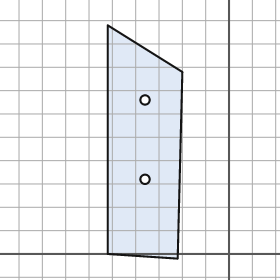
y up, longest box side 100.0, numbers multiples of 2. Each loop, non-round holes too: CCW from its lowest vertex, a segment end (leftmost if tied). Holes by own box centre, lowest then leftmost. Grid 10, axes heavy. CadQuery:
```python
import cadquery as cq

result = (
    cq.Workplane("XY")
    .moveTo(-22.0, -2.0)
    .lineTo(-20.0, 78.0)
    .lineTo(-52.0, 98.0)
    .lineTo(-52.0, 0.0)
    .close()
    .moveTo(-36.0, 32.0)
    .circle(2.0)
    .moveTo(-36.0, 66.0)
    .circle(2.0)
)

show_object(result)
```